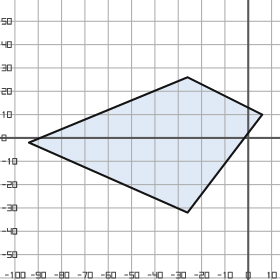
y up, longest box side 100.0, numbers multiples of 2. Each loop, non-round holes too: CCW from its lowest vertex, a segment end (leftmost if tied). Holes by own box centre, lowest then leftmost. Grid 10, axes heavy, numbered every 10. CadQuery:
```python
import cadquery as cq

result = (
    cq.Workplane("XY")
    .moveTo(-26.0, -32.0)
    .lineTo(6.0, 10.0)
    .lineTo(-26.0, 26.0)
    .lineTo(-94.0, -2.0)
    .close()
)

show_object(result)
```